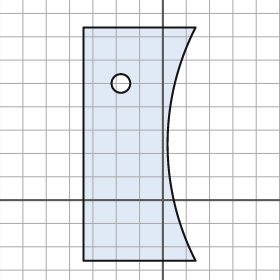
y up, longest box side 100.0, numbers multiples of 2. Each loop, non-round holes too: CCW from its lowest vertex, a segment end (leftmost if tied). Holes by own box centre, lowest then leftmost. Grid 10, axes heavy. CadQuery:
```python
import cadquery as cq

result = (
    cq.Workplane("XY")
    .moveTo(-34.0, -26.0)
    .lineTo(14.0, -26.0)
    .threePointArc((2.0, 24.0), (14.0, 74.0))
    .lineTo(-34.0, 74.0)
    .close()
    .moveTo(-18.0, 50.0)
    .circle(4.0)
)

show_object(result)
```